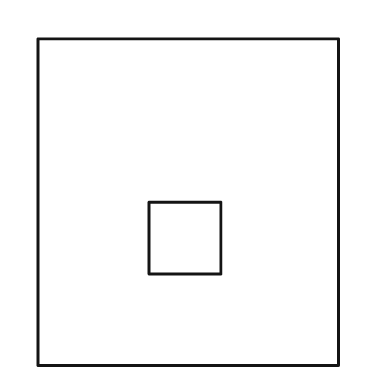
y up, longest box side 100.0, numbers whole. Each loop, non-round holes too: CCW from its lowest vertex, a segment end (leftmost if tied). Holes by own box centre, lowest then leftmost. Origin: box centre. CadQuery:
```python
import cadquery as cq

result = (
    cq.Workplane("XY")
    .moveTo(-46.0, -50.0)
    .lineTo(46.0, -50.0)
    .lineTo(46.0, 50.0)
    .lineTo(-46.0, 50.0)
    .close()
    .moveTo(-12.0, -22.0)
    .lineTo(10.0, -22.0)
    .lineTo(10.0, 0.0)
    .lineTo(-12.0, 0.0)
    .close()
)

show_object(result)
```